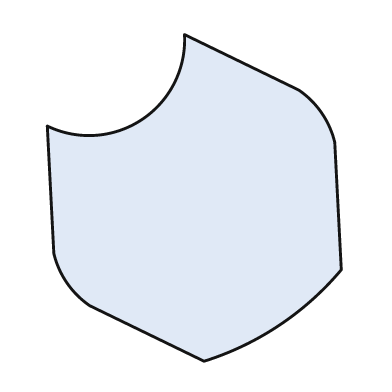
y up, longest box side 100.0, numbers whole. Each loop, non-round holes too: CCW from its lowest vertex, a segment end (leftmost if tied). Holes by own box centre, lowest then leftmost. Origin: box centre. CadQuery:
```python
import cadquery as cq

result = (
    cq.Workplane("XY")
    .moveTo(3.0, -50.0)
    .threePointArc((26.0, -39.0), (45.0, -22.0))
    .lineTo(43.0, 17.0)
    .threePointArc((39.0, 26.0), (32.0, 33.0))
    .lineTo(-3.0, 50.0)
    .threePointArc((-16.0, 24.0), (-45.0, 22.0))
    .lineTo(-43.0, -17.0)
    .threePointArc((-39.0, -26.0), (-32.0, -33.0))
    .close()
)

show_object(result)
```